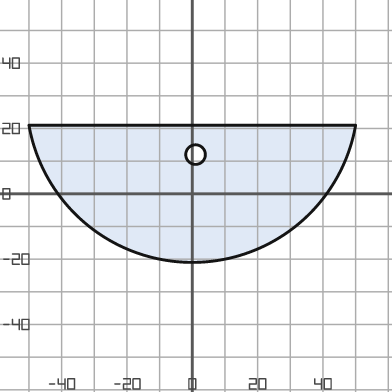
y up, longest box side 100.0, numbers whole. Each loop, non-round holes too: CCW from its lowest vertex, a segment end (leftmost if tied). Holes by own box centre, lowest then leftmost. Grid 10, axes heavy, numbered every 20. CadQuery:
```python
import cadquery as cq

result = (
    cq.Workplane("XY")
    .moveTo(-50.0, 21.0)
    .threePointArc((0.0, -21.0), (50.0, 21.0))
    .close()
    .moveTo(1.0, 12.0)
    .circle(3.0)
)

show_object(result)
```